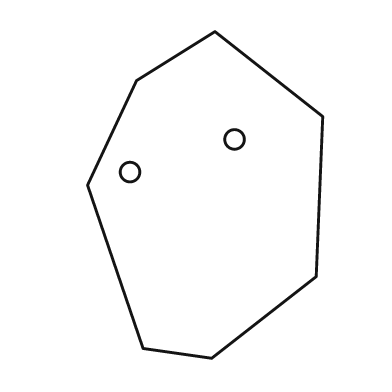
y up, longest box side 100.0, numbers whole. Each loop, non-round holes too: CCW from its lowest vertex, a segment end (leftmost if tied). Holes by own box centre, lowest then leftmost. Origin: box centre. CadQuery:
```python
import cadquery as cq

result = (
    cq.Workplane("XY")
    .moveTo(2.0, -50.0)
    .lineTo(34.0, -25.0)
    .lineTo(36.0, 24.0)
    .lineTo(3.0, 50.0)
    .lineTo(-21.0, 35.0)
    .lineTo(-36.0, 3.0)
    .lineTo(-19.0, -47.0)
    .close()
    .moveTo(-23.0, 7.0)
    .circle(3.0)
    .moveTo(9.0, 17.0)
    .circle(3.0)
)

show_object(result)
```